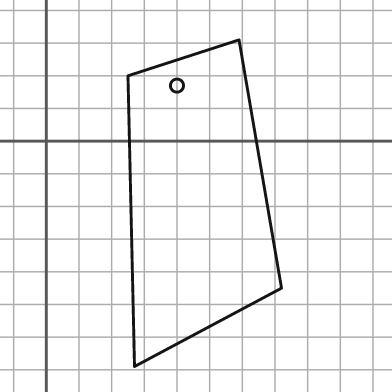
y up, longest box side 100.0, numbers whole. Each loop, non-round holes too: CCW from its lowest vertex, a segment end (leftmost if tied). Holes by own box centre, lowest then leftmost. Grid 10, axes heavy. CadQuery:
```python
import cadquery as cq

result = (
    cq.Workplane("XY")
    .moveTo(27.0, -69.0)
    .lineTo(72.0, -45.0)
    .lineTo(59.0, 31.0)
    .lineTo(25.0, 20.0)
    .close()
    .moveTo(40.0, 17.0)
    .circle(2.0)
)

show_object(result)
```